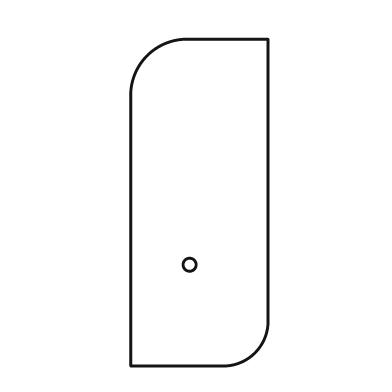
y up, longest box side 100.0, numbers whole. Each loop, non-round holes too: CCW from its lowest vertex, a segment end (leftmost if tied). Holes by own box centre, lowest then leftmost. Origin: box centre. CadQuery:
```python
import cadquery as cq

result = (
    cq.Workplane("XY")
    .moveTo(-21.0, -50.0)
    .lineTo(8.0, -50.0)
    .threePointArc((17.0, -46.0), (21.0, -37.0))
    .lineTo(21.0, 50.0)
    .lineTo(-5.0, 50.0)
    .threePointArc((-16.0, 45.0), (-21.0, 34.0))
    .close()
    .moveTo(-3.0, -19.0)
    .circle(2.0)
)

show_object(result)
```